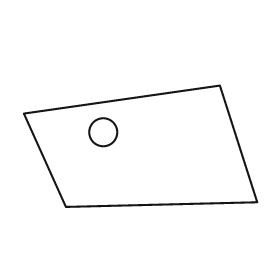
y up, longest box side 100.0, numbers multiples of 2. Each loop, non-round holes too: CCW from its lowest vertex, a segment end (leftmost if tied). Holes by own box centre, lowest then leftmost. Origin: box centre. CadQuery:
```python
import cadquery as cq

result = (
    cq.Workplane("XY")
    .moveTo(-32.0, -26.0)
    .lineTo(50.0, -24.0)
    .lineTo(34.0, 26.0)
    .lineTo(-50.0, 14.0)
    .close()
    .moveTo(-16.0, 6.0)
    .circle(6.0)
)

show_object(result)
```